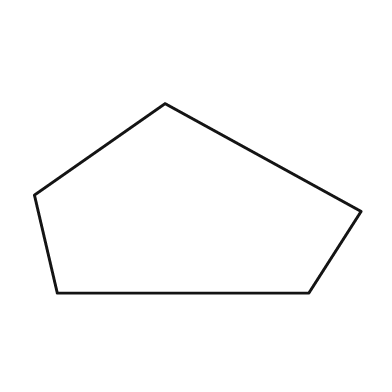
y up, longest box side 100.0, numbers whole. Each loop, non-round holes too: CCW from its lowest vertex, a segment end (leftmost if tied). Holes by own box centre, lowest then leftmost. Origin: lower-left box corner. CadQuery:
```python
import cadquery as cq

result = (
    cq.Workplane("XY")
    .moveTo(7.0, 0.0)
    .lineTo(84.0, 0.0)
    .lineTo(100.0, 25.0)
    .lineTo(40.0, 58.0)
    .lineTo(0.0, 30.0)
    .close()
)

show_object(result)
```